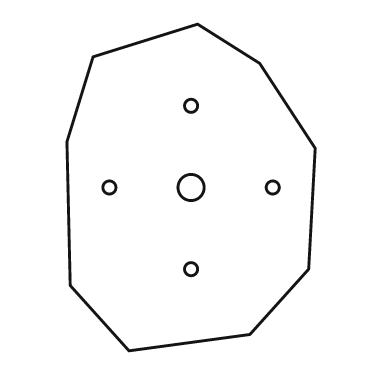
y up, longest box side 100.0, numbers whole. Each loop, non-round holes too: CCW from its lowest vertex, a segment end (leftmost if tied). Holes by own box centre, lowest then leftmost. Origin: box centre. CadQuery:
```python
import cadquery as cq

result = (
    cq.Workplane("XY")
    .moveTo(-19.0, -50.0)
    .lineTo(18.0, -45.0)
    .lineTo(36.0, -25.0)
    .lineTo(38.0, 12.0)
    .lineTo(21.0, 38.0)
    .lineTo(2.0, 50.0)
    .lineTo(-30.0, 40.0)
    .lineTo(-38.0, 14.0)
    .lineTo(-37.0, -30.0)
    .close()
    .moveTo(0.0, -25.0)
    .circle(2.0)
    .moveTo(-25.0, 0.0)
    .circle(2.0)
    .moveTo(0.0, 0.0)
    .circle(4.0)
    .moveTo(25.0, 0.0)
    .circle(2.0)
    .moveTo(0.0, 25.0)
    .circle(2.0)
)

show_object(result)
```